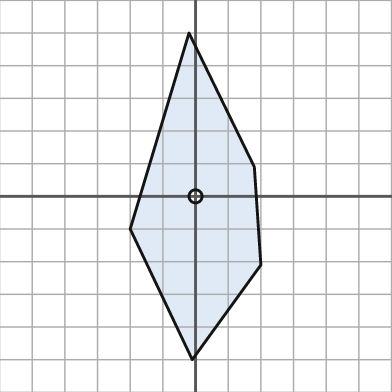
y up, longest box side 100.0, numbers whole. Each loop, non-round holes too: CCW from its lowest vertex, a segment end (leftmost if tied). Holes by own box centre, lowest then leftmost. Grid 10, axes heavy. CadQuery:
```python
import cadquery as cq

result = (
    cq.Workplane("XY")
    .moveTo(-1.0, -50.0)
    .lineTo(20.0, -21.0)
    .lineTo(18.0, 9.0)
    .lineTo(-2.0, 50.0)
    .lineTo(-20.0, -10.0)
    .close()
    .moveTo(0.0, 0.0)
    .circle(2.0)
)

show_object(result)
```